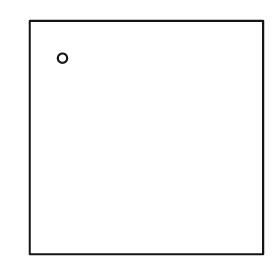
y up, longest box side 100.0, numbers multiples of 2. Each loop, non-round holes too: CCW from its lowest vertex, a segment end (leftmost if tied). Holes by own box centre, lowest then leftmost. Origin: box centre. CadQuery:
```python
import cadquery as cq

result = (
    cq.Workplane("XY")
    .moveTo(-50.0, -50.0)
    .lineTo(50.0, -50.0)
    .lineTo(50.0, 50.0)
    .lineTo(-50.0, 50.0)
    .close()
    .moveTo(-36.0, 34.0)
    .circle(2.0)
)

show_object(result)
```